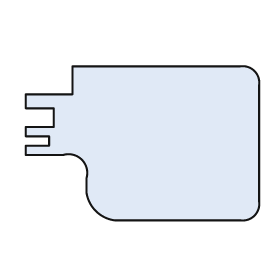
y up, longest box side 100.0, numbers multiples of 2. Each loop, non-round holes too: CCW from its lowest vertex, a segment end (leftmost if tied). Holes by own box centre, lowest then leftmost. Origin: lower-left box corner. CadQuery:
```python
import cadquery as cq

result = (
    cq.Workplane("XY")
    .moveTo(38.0, 0.0)
    .lineTo(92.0, 0.0)
    .threePointArc((98.0, 2.0), (100.0, 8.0))
    .lineTo(100.0, 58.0)
    .threePointArc((98.0, 64.0), (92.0, 66.0))
    .lineTo(20.0, 66.0)
    .lineTo(20.0, 54.0)
    .lineTo(0.0, 54.0)
    .lineTo(0.0, 48.0)
    .lineTo(12.0, 48.0)
    .lineTo(12.0, 40.0)
    .lineTo(0.0, 40.0)
    .lineTo(0.0, 36.0)
    .lineTo(10.0, 36.0)
    .lineTo(10.0, 32.0)
    .lineTo(0.0, 32.0)
    .lineTo(0.0, 28.0)
    .lineTo(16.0, 28.0)
    .threePointArc((24.0, 26.0), (26.0, 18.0))
    .lineTo(26.0, 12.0)
    .threePointArc((30.0, 4.0), (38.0, 0.0))
    .close()
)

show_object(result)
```